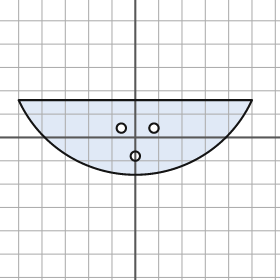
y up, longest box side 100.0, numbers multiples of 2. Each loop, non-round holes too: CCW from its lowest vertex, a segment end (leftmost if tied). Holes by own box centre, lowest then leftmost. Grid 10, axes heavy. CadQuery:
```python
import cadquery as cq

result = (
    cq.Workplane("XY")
    .moveTo(-50.0, 16.0)
    .threePointArc((0.0, -16.0), (50.0, 16.0))
    .close()
    .moveTo(0.0, -8.0)
    .circle(2.0)
    .moveTo(-6.0, 4.0)
    .circle(2.0)
    .moveTo(8.0, 4.0)
    .circle(2.0)
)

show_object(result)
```